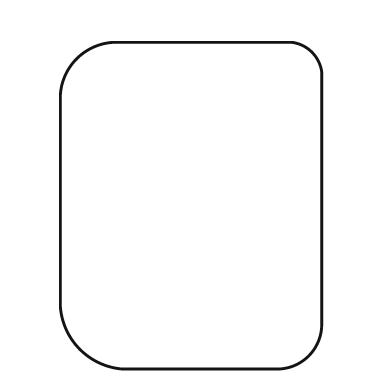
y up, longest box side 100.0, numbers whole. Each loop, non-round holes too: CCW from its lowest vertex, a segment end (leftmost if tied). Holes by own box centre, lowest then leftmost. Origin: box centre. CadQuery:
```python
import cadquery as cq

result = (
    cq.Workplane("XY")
    .moveTo(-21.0, -50.0)
    .lineTo(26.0, -50.0)
    .threePointArc((36.0, -46.0), (40.0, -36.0))
    .lineTo(40.0, 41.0)
    .threePointArc((37.0, 47.0), (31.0, 50.0))
    .lineTo(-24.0, 50.0)
    .threePointArc((-35.0, 45.0), (-40.0, 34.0))
    .lineTo(-40.0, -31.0)
    .threePointArc((-34.0, -44.0), (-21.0, -50.0))
    .close()
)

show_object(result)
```